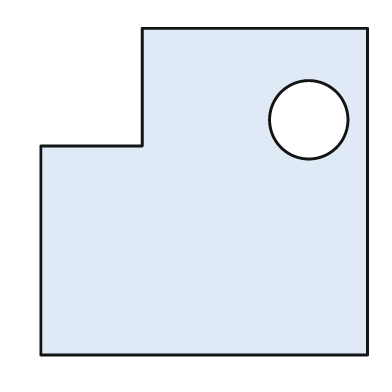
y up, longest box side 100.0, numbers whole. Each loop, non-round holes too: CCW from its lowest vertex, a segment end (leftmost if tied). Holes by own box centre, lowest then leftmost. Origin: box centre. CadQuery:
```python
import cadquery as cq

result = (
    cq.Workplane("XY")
    .moveTo(-50.0, -50.0)
    .lineTo(50.0, -50.0)
    .lineTo(50.0, 50.0)
    .lineTo(-19.0, 50.0)
    .lineTo(-19.0, 14.0)
    .lineTo(-50.0, 14.0)
    .close()
    .moveTo(32.0, 22.0)
    .circle(12.0)
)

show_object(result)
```